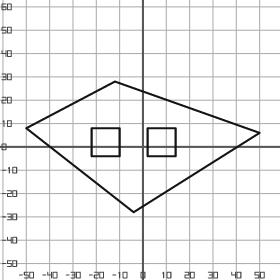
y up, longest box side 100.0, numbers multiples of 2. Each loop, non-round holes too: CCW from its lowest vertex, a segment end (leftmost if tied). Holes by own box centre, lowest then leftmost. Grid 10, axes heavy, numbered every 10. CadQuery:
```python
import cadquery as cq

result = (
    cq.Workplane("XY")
    .moveTo(-4.0, -28.0)
    .lineTo(50.0, 6.0)
    .lineTo(-12.0, 28.0)
    .lineTo(-50.0, 8.0)
    .close()
    .moveTo(-22.0, -4.0)
    .lineTo(-10.0, -4.0)
    .lineTo(-10.0, 8.0)
    .lineTo(-22.0, 8.0)
    .close()
    .moveTo(2.0, -4.0)
    .lineTo(14.0, -4.0)
    .lineTo(14.0, 8.0)
    .lineTo(2.0, 8.0)
    .close()
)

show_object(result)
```